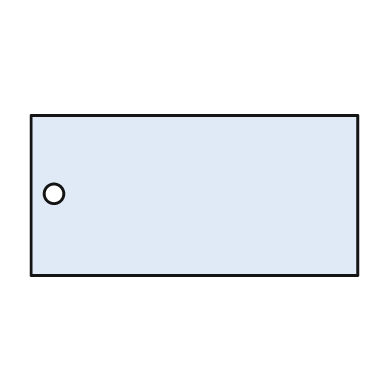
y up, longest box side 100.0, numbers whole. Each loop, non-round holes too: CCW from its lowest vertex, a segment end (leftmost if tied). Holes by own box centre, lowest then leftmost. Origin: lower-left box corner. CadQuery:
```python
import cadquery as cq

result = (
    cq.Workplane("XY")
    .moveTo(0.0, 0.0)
    .lineTo(100.0, 0.0)
    .lineTo(100.0, 49.0)
    .lineTo(0.0, 49.0)
    .close()
    .moveTo(7.0, 25.0)
    .circle(3.0)
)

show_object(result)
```